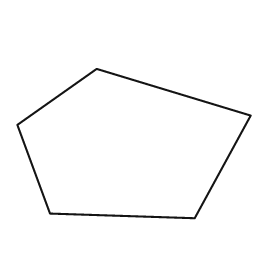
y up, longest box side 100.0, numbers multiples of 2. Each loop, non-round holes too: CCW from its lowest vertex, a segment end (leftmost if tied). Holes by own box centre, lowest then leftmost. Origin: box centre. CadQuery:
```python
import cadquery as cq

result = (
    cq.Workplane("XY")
    .moveTo(26.0, -32.0)
    .lineTo(50.0, 12.0)
    .lineTo(-16.0, 32.0)
    .lineTo(-50.0, 8.0)
    .lineTo(-36.0, -30.0)
    .close()
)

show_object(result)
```